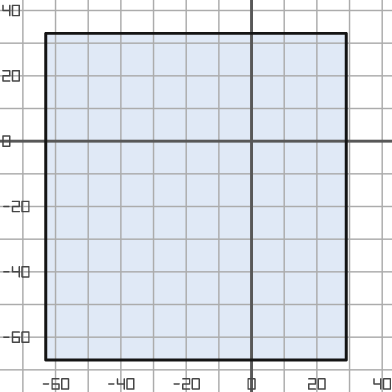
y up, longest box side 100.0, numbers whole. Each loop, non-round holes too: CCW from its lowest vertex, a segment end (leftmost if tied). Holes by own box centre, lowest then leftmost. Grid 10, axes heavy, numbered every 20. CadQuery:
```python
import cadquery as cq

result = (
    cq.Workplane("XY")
    .moveTo(-63.0, -67.0)
    .lineTo(29.0, -67.0)
    .lineTo(29.0, 33.0)
    .lineTo(-63.0, 33.0)
    .close()
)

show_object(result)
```